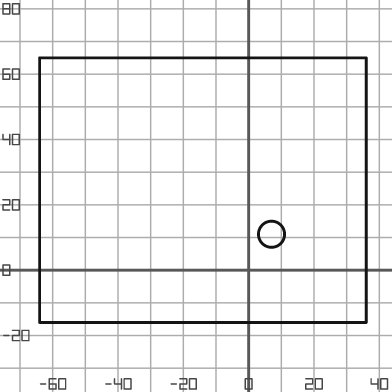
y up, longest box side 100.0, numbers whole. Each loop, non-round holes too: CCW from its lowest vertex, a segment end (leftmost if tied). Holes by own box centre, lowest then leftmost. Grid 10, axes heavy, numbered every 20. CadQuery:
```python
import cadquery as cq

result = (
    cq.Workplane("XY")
    .moveTo(-64.0, -16.0)
    .lineTo(36.0, -16.0)
    .lineTo(36.0, 65.0)
    .lineTo(-64.0, 65.0)
    .close()
    .moveTo(7.0, 11.0)
    .circle(4.0)
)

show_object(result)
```